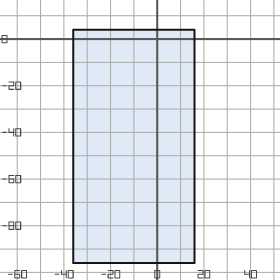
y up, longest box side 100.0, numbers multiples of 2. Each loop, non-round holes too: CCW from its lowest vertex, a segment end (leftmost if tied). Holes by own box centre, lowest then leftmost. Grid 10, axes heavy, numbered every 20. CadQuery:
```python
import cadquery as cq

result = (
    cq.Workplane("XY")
    .moveTo(-36.0, -96.0)
    .lineTo(16.0, -96.0)
    .lineTo(16.0, 4.0)
    .lineTo(-36.0, 4.0)
    .close()
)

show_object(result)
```